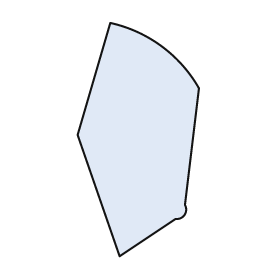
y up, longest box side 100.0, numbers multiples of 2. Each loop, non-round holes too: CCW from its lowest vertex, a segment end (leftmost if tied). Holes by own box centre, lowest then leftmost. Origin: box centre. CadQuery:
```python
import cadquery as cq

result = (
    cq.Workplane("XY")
    .moveTo(-8.0, -50.0)
    .lineTo(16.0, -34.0)
    .threePointArc((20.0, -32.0), (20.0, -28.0))
    .lineTo(26.0, 22.0)
    .threePointArc((10.0, 40.0), (-12.0, 50.0))
    .lineTo(-26.0, 2.0)
    .close()
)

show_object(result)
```